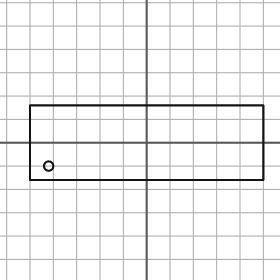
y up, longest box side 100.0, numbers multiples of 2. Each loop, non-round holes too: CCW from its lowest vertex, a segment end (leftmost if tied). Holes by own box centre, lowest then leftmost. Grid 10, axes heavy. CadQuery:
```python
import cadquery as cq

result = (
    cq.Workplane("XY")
    .moveTo(-50.0, -16.0)
    .lineTo(50.0, -16.0)
    .lineTo(50.0, 16.0)
    .lineTo(-50.0, 16.0)
    .close()
    .moveTo(-42.0, -10.0)
    .circle(2.0)
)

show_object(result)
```